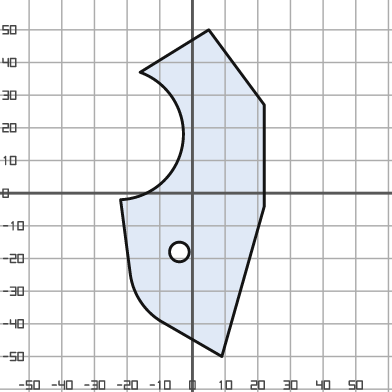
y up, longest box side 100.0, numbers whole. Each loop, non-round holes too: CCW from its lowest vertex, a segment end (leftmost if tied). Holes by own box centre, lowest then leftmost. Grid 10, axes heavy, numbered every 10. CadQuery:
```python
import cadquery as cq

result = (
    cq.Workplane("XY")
    .moveTo(9.0, -50.0)
    .lineTo(22.0, -4.0)
    .lineTo(22.0, 27.0)
    .lineTo(5.0, 50.0)
    .lineTo(-16.0, 37.0)
    .threePointArc((-3.0, 15.0), (-22.0, -2.0))
    .lineTo(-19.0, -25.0)
    .threePointArc((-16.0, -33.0), (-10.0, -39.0))
    .close()
    .moveTo(-4.0, -18.0)
    .circle(3.0)
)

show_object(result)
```